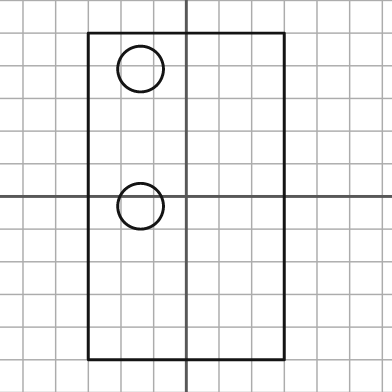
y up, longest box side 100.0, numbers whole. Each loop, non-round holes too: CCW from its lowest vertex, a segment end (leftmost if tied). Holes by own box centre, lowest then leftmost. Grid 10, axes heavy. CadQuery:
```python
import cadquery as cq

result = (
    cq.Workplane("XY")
    .moveTo(-30.0, -50.0)
    .lineTo(30.0, -50.0)
    .lineTo(30.0, 50.0)
    .lineTo(-30.0, 50.0)
    .close()
    .moveTo(-14.0, -3.0)
    .circle(7.0)
    .moveTo(-14.0, 39.0)
    .circle(7.0)
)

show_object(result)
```